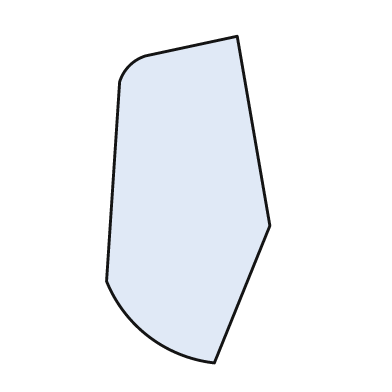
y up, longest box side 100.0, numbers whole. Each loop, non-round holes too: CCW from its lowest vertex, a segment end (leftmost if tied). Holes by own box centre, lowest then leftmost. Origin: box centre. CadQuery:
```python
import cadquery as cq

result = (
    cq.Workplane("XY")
    .moveTo(8.0, -50.0)
    .lineTo(25.0, -8.0)
    .lineTo(15.0, 50.0)
    .lineTo(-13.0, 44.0)
    .threePointArc((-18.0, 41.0), (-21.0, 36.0))
    .lineTo(-25.0, -25.0)
    .threePointArc((-12.0, -42.0), (8.0, -50.0))
    .close()
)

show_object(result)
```